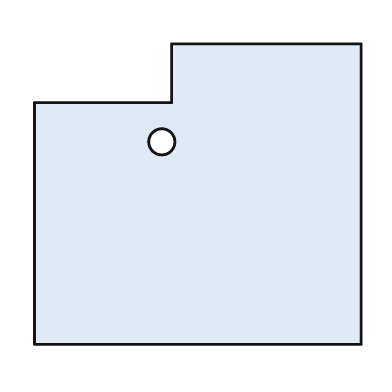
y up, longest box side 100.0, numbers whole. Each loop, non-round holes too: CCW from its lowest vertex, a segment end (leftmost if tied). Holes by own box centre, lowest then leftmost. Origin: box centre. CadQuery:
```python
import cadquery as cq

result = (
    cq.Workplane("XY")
    .moveTo(-50.0, -46.0)
    .lineTo(50.0, -46.0)
    .lineTo(50.0, 46.0)
    .lineTo(-8.0, 46.0)
    .lineTo(-8.0, 28.0)
    .lineTo(-50.0, 28.0)
    .close()
    .moveTo(-11.0, 16.0)
    .circle(4.0)
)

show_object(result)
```